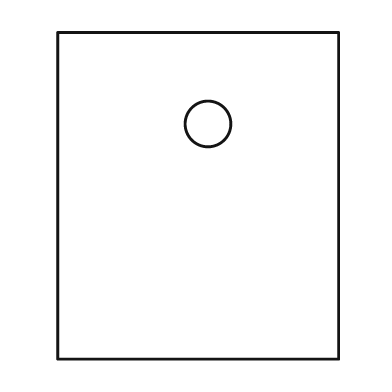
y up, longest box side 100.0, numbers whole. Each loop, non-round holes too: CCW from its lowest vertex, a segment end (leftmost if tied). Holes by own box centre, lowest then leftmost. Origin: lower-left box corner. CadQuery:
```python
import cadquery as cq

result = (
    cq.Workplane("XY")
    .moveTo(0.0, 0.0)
    .lineTo(86.0, 0.0)
    .lineTo(86.0, 100.0)
    .lineTo(0.0, 100.0)
    .close()
    .moveTo(46.0, 72.0)
    .circle(7.0)
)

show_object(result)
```